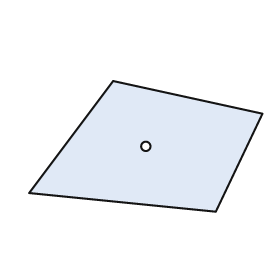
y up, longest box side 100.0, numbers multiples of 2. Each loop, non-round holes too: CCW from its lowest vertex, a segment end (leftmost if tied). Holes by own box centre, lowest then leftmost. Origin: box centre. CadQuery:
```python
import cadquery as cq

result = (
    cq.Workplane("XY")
    .moveTo(30.0, -28.0)
    .lineTo(50.0, 14.0)
    .lineTo(-14.0, 28.0)
    .lineTo(-50.0, -20.0)
    .close()
    .moveTo(0.0, 0.0)
    .circle(2.0)
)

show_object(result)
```